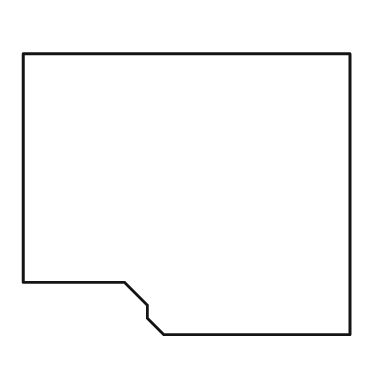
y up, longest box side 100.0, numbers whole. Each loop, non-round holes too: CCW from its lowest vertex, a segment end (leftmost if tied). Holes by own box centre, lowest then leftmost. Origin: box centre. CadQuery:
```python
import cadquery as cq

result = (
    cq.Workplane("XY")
    .moveTo(-7.0, -43.0)
    .lineTo(50.0, -43.0)
    .lineTo(50.0, 43.0)
    .lineTo(-50.0, 43.0)
    .lineTo(-50.0, -27.0)
    .lineTo(-19.0, -27.0)
    .lineTo(-12.0, -34.0)
    .lineTo(-12.0, -38.0)
    .close()
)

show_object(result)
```